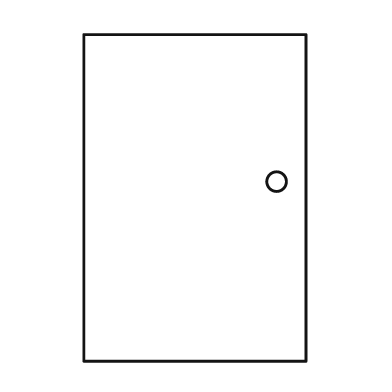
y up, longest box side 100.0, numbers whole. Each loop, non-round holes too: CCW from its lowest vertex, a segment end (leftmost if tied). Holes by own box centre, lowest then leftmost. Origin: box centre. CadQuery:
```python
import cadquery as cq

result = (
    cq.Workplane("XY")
    .moveTo(-34.0, -50.0)
    .lineTo(34.0, -50.0)
    .lineTo(34.0, 50.0)
    .lineTo(-34.0, 50.0)
    .close()
    .moveTo(25.0, 5.0)
    .circle(3.0)
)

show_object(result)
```